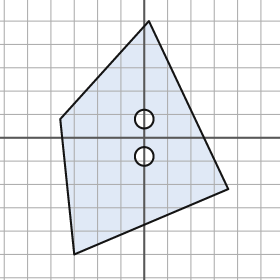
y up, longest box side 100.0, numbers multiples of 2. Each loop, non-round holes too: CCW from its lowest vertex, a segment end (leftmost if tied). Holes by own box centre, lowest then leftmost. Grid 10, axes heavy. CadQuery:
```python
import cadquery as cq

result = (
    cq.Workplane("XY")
    .moveTo(-30.0, -50.0)
    .lineTo(36.0, -22.0)
    .lineTo(2.0, 50.0)
    .lineTo(-36.0, 8.0)
    .close()
    .moveTo(0.0, -8.0)
    .circle(4.0)
    .moveTo(0.0, 8.0)
    .circle(4.0)
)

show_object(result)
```